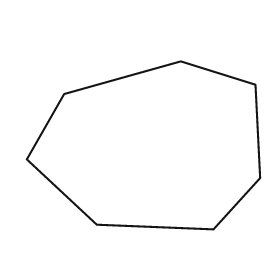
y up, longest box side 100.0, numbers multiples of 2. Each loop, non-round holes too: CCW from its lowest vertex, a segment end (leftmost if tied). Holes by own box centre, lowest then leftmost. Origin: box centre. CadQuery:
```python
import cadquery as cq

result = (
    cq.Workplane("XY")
    .moveTo(30.0, -36.0)
    .lineTo(50.0, -14.0)
    .lineTo(48.0, 26.0)
    .lineTo(16.0, 36.0)
    .lineTo(-34.0, 22.0)
    .lineTo(-50.0, -6.0)
    .lineTo(-20.0, -34.0)
    .close()
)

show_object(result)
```